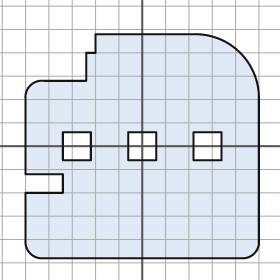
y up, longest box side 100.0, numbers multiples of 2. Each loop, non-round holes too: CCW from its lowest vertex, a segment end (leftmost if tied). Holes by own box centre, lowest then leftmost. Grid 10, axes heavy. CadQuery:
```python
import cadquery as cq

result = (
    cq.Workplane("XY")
    .moveTo(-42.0, -48.0)
    .lineTo(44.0, -48.0)
    .threePointArc((48.0, -46.0), (50.0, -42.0))
    .lineTo(50.0, 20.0)
    .threePointArc((42.0, 40.0), (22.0, 48.0))
    .lineTo(-20.0, 48.0)
    .lineTo(-20.0, 40.0)
    .lineTo(-24.0, 40.0)
    .lineTo(-24.0, 28.0)
    .lineTo(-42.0, 28.0)
    .threePointArc((-48.0, 26.0), (-50.0, 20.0))
    .lineTo(-50.0, -12.0)
    .lineTo(-34.0, -12.0)
    .lineTo(-34.0, -20.0)
    .lineTo(-50.0, -20.0)
    .lineTo(-50.0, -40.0)
    .threePointArc((-48.0, -46.0), (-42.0, -48.0))
    .close()
    .moveTo(-34.0, -6.0)
    .lineTo(-22.0, -6.0)
    .lineTo(-22.0, 6.0)
    .lineTo(-34.0, 6.0)
    .close()
    .moveTo(-6.0, -6.0)
    .lineTo(6.0, -6.0)
    .lineTo(6.0, 6.0)
    .lineTo(-6.0, 6.0)
    .close()
    .moveTo(22.0, -6.0)
    .lineTo(34.0, -6.0)
    .lineTo(34.0, 6.0)
    .lineTo(22.0, 6.0)
    .close()
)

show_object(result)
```